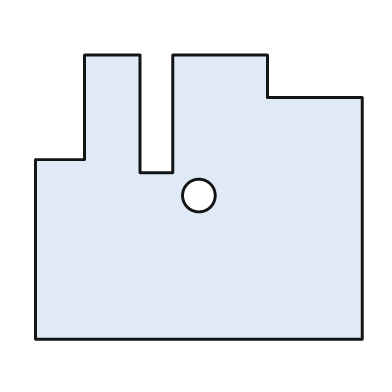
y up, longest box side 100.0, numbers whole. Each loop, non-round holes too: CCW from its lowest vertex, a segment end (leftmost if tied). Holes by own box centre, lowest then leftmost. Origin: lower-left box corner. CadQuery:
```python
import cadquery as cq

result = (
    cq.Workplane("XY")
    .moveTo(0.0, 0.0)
    .lineTo(100.0, 0.0)
    .lineTo(100.0, 74.0)
    .lineTo(71.0, 74.0)
    .lineTo(71.0, 87.0)
    .lineTo(42.0, 87.0)
    .lineTo(42.0, 51.0)
    .lineTo(32.0, 51.0)
    .lineTo(32.0, 87.0)
    .lineTo(15.0, 87.0)
    .lineTo(15.0, 55.0)
    .lineTo(0.0, 55.0)
    .close()
    .moveTo(50.0, 44.0)
    .circle(5.0)
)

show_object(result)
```